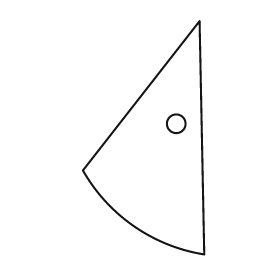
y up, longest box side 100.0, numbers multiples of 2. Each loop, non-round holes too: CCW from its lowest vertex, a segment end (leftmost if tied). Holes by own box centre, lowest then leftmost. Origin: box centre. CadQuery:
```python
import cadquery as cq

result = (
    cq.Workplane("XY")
    .moveTo(26.0, -50.0)
    .lineTo(24.0, 50.0)
    .lineTo(-26.0, -14.0)
    .threePointArc((-4.0, -38.0), (26.0, -50.0))
    .close()
    .moveTo(14.0, 6.0)
    .circle(4.0)
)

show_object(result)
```